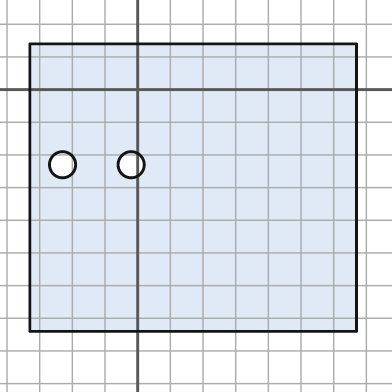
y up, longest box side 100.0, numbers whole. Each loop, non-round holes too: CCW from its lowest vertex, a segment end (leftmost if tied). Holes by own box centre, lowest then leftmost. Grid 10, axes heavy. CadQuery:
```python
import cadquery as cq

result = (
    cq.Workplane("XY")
    .moveTo(-33.0, -74.0)
    .lineTo(67.0, -74.0)
    .lineTo(67.0, 14.0)
    .lineTo(-33.0, 14.0)
    .close()
    .moveTo(-23.0, -23.0)
    .circle(4.0)
    .moveTo(-2.0, -23.0)
    .circle(4.0)
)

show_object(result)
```